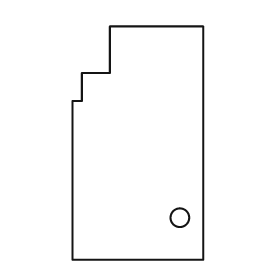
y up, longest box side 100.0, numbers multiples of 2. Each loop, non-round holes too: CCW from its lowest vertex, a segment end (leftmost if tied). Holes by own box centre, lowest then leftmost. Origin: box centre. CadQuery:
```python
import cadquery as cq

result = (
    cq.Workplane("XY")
    .moveTo(-28.0, -50.0)
    .lineTo(28.0, -50.0)
    .lineTo(28.0, 50.0)
    .lineTo(-12.0, 50.0)
    .lineTo(-12.0, 30.0)
    .lineTo(-24.0, 30.0)
    .lineTo(-24.0, 18.0)
    .lineTo(-28.0, 18.0)
    .close()
    .moveTo(18.0, -32.0)
    .circle(4.0)
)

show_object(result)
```